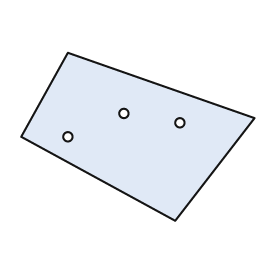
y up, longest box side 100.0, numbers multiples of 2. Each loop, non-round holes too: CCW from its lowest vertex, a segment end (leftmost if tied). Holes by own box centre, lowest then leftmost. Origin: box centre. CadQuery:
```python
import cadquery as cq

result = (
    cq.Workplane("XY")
    .moveTo(16.0, -36.0)
    .lineTo(50.0, 8.0)
    .lineTo(-30.0, 36.0)
    .lineTo(-50.0, 0.0)
    .close()
    .moveTo(-30.0, 0.0)
    .circle(2.0)
    .moveTo(18.0, 6.0)
    .circle(2.0)
    .moveTo(-6.0, 10.0)
    .circle(2.0)
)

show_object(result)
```